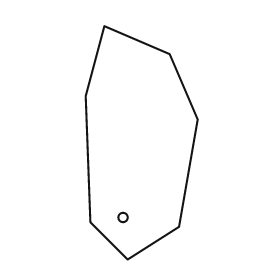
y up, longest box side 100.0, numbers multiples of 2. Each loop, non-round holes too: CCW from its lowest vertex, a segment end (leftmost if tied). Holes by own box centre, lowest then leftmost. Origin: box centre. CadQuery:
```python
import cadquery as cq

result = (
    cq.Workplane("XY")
    .moveTo(-6.0, -50.0)
    .lineTo(16.0, -36.0)
    .lineTo(24.0, 10.0)
    .lineTo(12.0, 38.0)
    .lineTo(-16.0, 50.0)
    .lineTo(-24.0, 20.0)
    .lineTo(-22.0, -34.0)
    .close()
    .moveTo(-8.0, -32.0)
    .circle(2.0)
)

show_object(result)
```